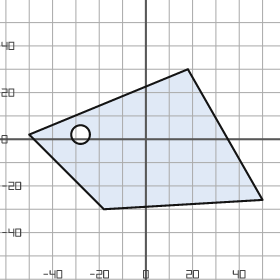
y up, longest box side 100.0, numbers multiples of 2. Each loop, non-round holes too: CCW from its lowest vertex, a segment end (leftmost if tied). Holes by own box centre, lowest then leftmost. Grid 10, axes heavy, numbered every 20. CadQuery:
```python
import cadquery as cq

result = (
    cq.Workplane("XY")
    .moveTo(-18.0, -30.0)
    .lineTo(50.0, -26.0)
    .lineTo(18.0, 30.0)
    .lineTo(-50.0, 2.0)
    .close()
    .moveTo(-28.0, 2.0)
    .circle(4.0)
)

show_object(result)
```